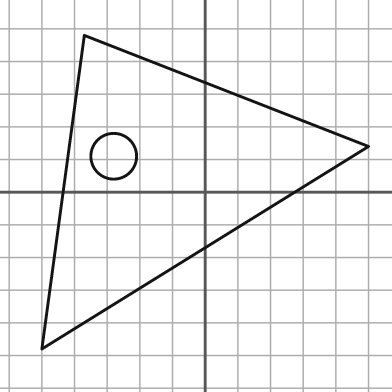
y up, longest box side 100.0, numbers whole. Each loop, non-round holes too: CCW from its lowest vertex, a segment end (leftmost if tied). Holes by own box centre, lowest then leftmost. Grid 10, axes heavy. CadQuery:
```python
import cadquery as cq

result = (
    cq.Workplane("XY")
    .moveTo(-50.0, -48.0)
    .lineTo(50.0, 14.0)
    .lineTo(-37.0, 48.0)
    .close()
    .moveTo(-28.0, 11.0)
    .circle(7.0)
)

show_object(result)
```